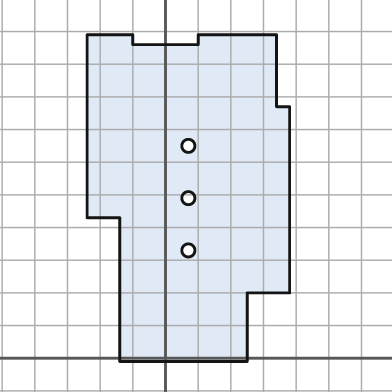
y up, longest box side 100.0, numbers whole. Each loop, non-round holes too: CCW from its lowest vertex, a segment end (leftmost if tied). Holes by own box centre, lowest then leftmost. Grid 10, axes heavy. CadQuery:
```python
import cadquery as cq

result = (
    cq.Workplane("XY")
    .moveTo(-14.0, -1.0)
    .lineTo(25.0, -1.0)
    .lineTo(25.0, 20.0)
    .lineTo(38.0, 20.0)
    .lineTo(38.0, 77.0)
    .lineTo(34.0, 77.0)
    .lineTo(34.0, 99.0)
    .lineTo(10.0, 99.0)
    .lineTo(10.0, 96.0)
    .lineTo(-10.0, 96.0)
    .lineTo(-10.0, 99.0)
    .lineTo(-24.0, 99.0)
    .lineTo(-24.0, 43.0)
    .lineTo(-14.0, 43.0)
    .close()
    .moveTo(7.0, 33.0)
    .circle(2.0)
    .moveTo(7.0, 49.0)
    .circle(2.0)
    .moveTo(7.0, 65.0)
    .circle(2.0)
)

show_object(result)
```